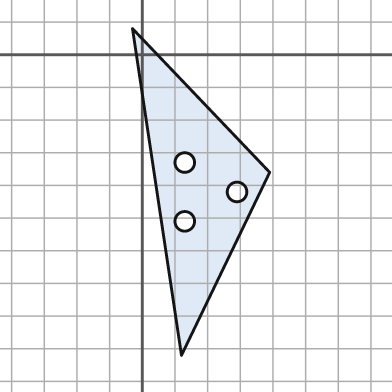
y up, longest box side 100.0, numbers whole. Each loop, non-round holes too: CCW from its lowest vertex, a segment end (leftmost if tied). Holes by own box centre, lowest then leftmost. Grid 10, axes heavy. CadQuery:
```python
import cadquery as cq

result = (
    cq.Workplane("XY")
    .moveTo(12.0, -92.0)
    .lineTo(39.0, -36.0)
    .lineTo(-3.0, 8.0)
    .close()
    .moveTo(13.0, -51.0)
    .circle(3.0)
    .moveTo(29.0, -42.0)
    .circle(3.0)
    .moveTo(13.0, -33.0)
    .circle(3.0)
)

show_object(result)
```